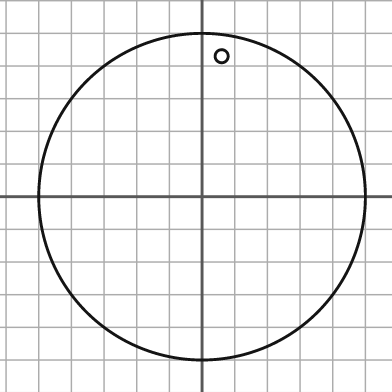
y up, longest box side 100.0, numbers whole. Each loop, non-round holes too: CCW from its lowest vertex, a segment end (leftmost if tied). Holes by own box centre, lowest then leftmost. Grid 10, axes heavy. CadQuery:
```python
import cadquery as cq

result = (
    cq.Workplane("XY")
    .moveTo(0.0, 0.0)
    .circle(50.0)
    .moveTo(6.0, 43.0)
    .circle(2.0)
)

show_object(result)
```